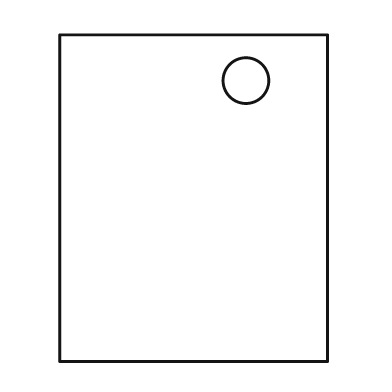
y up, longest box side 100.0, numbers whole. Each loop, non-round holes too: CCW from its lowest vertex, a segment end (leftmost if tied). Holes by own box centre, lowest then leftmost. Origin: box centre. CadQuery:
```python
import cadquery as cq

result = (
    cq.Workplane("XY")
    .moveTo(-41.0, -50.0)
    .lineTo(41.0, -50.0)
    .lineTo(41.0, 50.0)
    .lineTo(-41.0, 50.0)
    .close()
    .moveTo(16.0, 36.0)
    .circle(7.0)
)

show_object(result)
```